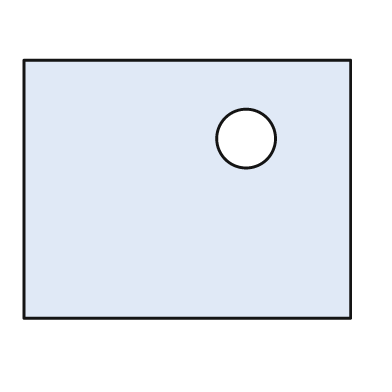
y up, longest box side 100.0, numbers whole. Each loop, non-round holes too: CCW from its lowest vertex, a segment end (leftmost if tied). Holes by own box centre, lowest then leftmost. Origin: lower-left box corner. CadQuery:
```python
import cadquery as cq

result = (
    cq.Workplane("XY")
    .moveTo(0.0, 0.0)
    .lineTo(100.0, 0.0)
    .lineTo(100.0, 79.0)
    .lineTo(0.0, 79.0)
    .close()
    .moveTo(68.0, 55.0)
    .circle(9.0)
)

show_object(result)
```